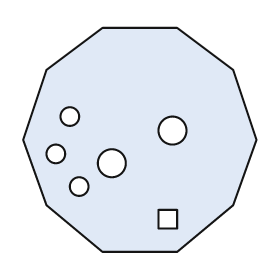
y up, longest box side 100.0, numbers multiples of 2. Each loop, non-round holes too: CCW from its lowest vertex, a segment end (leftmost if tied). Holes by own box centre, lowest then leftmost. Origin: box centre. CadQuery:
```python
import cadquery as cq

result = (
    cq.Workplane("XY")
    .moveTo(-16.0, -48.0)
    .lineTo(16.0, -48.0)
    .lineTo(40.0, -28.0)
    .lineTo(50.0, 0.0)
    .lineTo(40.0, 30.0)
    .lineTo(16.0, 48.0)
    .lineTo(-16.0, 48.0)
    .lineTo(-40.0, 30.0)
    .lineTo(-50.0, 0.0)
    .lineTo(-40.0, -28.0)
    .close()
    .moveTo(8.0, -38.0)
    .lineTo(16.0, -38.0)
    .lineTo(16.0, -30.0)
    .lineTo(8.0, -30.0)
    .close()
    .moveTo(-26.0, -20.0)
    .circle(4.0)
    .moveTo(-12.0, -10.0)
    .circle(6.0)
    .moveTo(-36.0, -6.0)
    .circle(4.0)
    .moveTo(14.0, 4.0)
    .circle(6.0)
    .moveTo(-30.0, 10.0)
    .circle(4.0)
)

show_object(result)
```